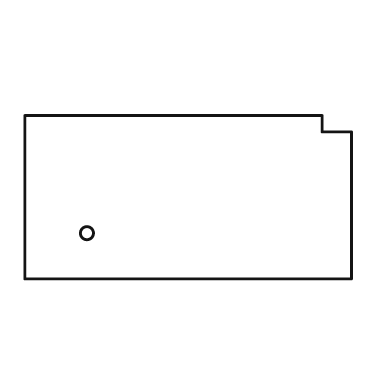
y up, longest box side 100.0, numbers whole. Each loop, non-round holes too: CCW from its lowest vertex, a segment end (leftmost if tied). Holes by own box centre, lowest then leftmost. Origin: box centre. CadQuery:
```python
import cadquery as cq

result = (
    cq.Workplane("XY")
    .moveTo(-50.0, -25.0)
    .lineTo(50.0, -25.0)
    .lineTo(50.0, 20.0)
    .lineTo(41.0, 20.0)
    .lineTo(41.0, 25.0)
    .lineTo(-50.0, 25.0)
    .close()
    .moveTo(-31.0, -11.0)
    .circle(2.0)
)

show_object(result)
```